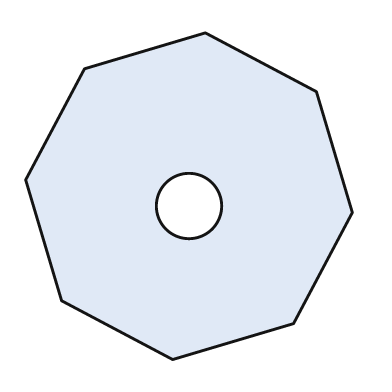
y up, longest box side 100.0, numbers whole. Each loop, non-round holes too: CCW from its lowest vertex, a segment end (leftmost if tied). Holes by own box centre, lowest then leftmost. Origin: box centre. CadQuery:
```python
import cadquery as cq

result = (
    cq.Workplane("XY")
    .moveTo(-5.0, -50.0)
    .lineTo(32.0, -39.0)
    .lineTo(50.0, -5.0)
    .lineTo(39.0, 32.0)
    .lineTo(5.0, 50.0)
    .lineTo(-32.0, 39.0)
    .lineTo(-50.0, 5.0)
    .lineTo(-39.0, -32.0)
    .close()
    .moveTo(0.0, -3.0)
    .circle(10.0)
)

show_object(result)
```